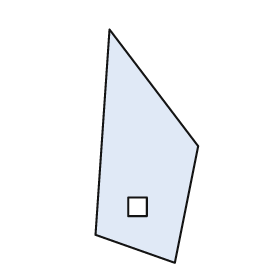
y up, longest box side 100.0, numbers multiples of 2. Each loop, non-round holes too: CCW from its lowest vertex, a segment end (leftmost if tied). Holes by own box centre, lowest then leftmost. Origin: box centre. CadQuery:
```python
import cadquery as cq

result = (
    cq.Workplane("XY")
    .moveTo(12.0, -50.0)
    .lineTo(22.0, 0.0)
    .lineTo(-16.0, 50.0)
    .lineTo(-22.0, -38.0)
    .close()
    .moveTo(-8.0, -30.0)
    .lineTo(0.0, -30.0)
    .lineTo(0.0, -22.0)
    .lineTo(-8.0, -22.0)
    .close()
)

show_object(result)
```